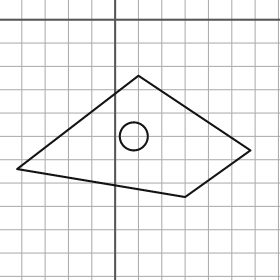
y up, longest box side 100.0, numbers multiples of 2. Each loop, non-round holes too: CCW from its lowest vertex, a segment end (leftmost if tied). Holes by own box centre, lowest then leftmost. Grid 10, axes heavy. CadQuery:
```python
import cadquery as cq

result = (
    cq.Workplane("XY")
    .moveTo(30.0, -76.0)
    .lineTo(58.0, -56.0)
    .lineTo(10.0, -24.0)
    .lineTo(-42.0, -64.0)
    .close()
    .moveTo(8.0, -50.0)
    .circle(6.0)
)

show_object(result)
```